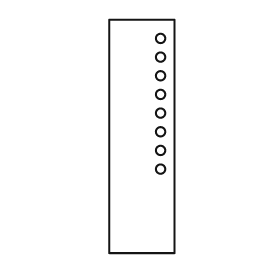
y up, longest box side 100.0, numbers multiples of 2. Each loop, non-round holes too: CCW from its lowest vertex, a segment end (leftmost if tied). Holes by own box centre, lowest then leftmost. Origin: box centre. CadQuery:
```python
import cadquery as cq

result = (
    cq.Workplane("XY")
    .moveTo(-14.0, -50.0)
    .lineTo(14.0, -50.0)
    .lineTo(14.0, 50.0)
    .lineTo(-14.0, 50.0)
    .close()
    .moveTo(8.0, -14.0)
    .circle(2.0)
    .moveTo(8.0, -6.0)
    .circle(2.0)
    .moveTo(8.0, 2.0)
    .circle(2.0)
    .moveTo(8.0, 10.0)
    .circle(2.0)
    .moveTo(8.0, 18.0)
    .circle(2.0)
    .moveTo(8.0, 26.0)
    .circle(2.0)
    .moveTo(8.0, 34.0)
    .circle(2.0)
    .moveTo(8.0, 42.0)
    .circle(2.0)
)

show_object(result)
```